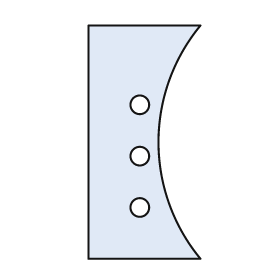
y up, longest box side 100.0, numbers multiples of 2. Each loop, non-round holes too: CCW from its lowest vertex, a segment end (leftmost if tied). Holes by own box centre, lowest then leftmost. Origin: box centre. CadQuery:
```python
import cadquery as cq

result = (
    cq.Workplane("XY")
    .moveTo(-24.0, -50.0)
    .lineTo(24.0, -50.0)
    .threePointArc((6.0, 0.0), (24.0, 50.0))
    .lineTo(-24.0, 50.0)
    .close()
    .moveTo(-2.0, -28.0)
    .circle(4.0)
    .moveTo(-2.0, -6.0)
    .circle(4.0)
    .moveTo(-2.0, 16.0)
    .circle(4.0)
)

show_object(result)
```